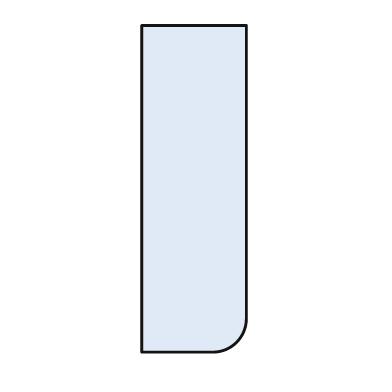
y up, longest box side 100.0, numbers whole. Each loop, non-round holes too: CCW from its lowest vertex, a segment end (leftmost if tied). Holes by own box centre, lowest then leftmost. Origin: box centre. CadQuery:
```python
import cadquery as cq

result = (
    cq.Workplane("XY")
    .moveTo(-16.0, -50.0)
    .lineTo(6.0, -50.0)
    .threePointArc((13.0, -47.0), (16.0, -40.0))
    .lineTo(16.0, 50.0)
    .lineTo(-16.0, 50.0)
    .close()
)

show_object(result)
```